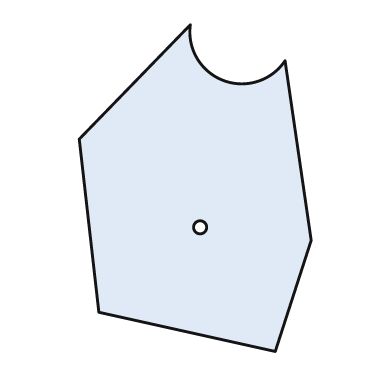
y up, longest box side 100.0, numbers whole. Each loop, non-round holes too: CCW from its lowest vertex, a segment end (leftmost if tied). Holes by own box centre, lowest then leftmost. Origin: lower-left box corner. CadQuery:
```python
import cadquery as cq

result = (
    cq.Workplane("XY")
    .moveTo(60.0, 0.0)
    .lineTo(71.0, 34.0)
    .lineTo(63.0, 89.0)
    .threePointArc((44.0, 83.0), (34.0, 100.0))
    .lineTo(0.0, 65.0)
    .lineTo(6.0, 12.0)
    .close()
    .moveTo(37.0, 38.0)
    .circle(2.0)
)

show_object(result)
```